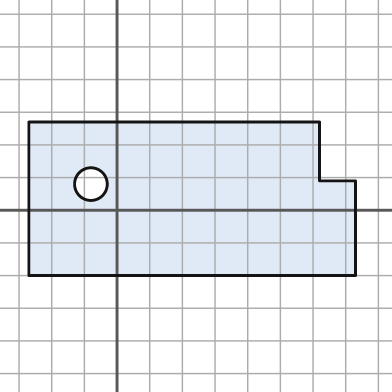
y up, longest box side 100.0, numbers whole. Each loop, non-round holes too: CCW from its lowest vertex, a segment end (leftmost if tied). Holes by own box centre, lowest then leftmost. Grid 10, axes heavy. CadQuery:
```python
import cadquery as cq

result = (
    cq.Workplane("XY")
    .moveTo(-27.0, -20.0)
    .lineTo(73.0, -20.0)
    .lineTo(73.0, 9.0)
    .lineTo(62.0, 9.0)
    .lineTo(62.0, 27.0)
    .lineTo(-27.0, 27.0)
    .close()
    .moveTo(-8.0, 8.0)
    .circle(5.0)
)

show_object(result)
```